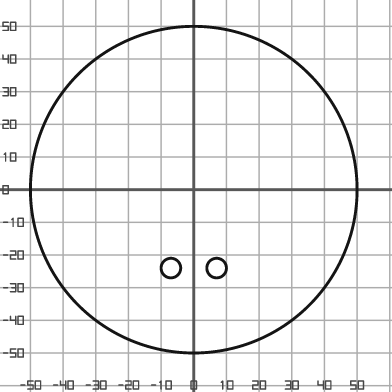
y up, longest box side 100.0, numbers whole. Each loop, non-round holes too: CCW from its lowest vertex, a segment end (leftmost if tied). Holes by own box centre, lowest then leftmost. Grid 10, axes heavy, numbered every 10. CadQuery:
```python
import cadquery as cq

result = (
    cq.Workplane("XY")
    .moveTo(0.0, 0.0)
    .circle(50.0)
    .moveTo(-7.0, -24.0)
    .circle(3.0)
    .moveTo(7.0, -24.0)
    .circle(3.0)
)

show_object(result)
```